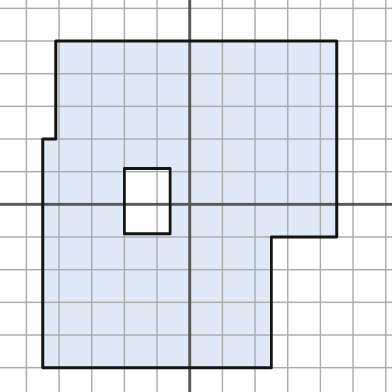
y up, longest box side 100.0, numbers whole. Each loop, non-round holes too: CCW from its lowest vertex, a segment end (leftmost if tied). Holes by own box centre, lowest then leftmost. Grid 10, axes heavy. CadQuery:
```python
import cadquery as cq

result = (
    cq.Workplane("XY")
    .moveTo(-45.0, -50.0)
    .lineTo(25.0, -50.0)
    .lineTo(25.0, -10.0)
    .lineTo(45.0, -10.0)
    .lineTo(45.0, 50.0)
    .lineTo(-41.0, 50.0)
    .lineTo(-41.0, 20.0)
    .lineTo(-45.0, 20.0)
    .close()
    .moveTo(-20.0, -9.0)
    .lineTo(-6.0, -9.0)
    .lineTo(-6.0, 11.0)
    .lineTo(-20.0, 11.0)
    .close()
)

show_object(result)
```